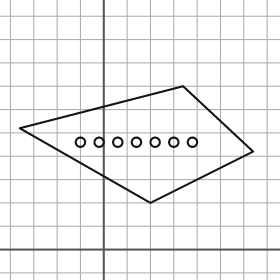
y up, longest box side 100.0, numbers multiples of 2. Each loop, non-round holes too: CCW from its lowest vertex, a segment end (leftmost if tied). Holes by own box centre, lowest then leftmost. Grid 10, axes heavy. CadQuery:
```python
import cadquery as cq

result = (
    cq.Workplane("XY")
    .moveTo(20.0, 20.0)
    .lineTo(64.0, 42.0)
    .lineTo(34.0, 70.0)
    .lineTo(-36.0, 52.0)
    .close()
    .moveTo(-10.0, 46.0)
    .circle(2.0)
    .moveTo(-2.0, 46.0)
    .circle(2.0)
    .moveTo(6.0, 46.0)
    .circle(2.0)
    .moveTo(14.0, 46.0)
    .circle(2.0)
    .moveTo(22.0, 46.0)
    .circle(2.0)
    .moveTo(30.0, 46.0)
    .circle(2.0)
    .moveTo(38.0, 46.0)
    .circle(2.0)
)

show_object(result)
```